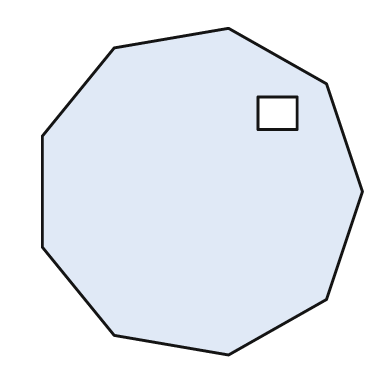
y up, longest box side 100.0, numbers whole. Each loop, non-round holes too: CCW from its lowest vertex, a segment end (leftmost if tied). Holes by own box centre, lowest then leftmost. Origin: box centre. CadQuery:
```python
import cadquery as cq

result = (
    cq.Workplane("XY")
    .moveTo(8.0, -50.0)
    .lineTo(38.0, -33.0)
    .lineTo(49.0, 0.0)
    .lineTo(38.0, 33.0)
    .lineTo(8.0, 50.0)
    .lineTo(-27.0, 44.0)
    .lineTo(-49.0, 17.0)
    .lineTo(-49.0, -17.0)
    .lineTo(-27.0, -44.0)
    .close()
    .moveTo(17.0, 19.0)
    .lineTo(29.0, 19.0)
    .lineTo(29.0, 29.0)
    .lineTo(17.0, 29.0)
    .close()
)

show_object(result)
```